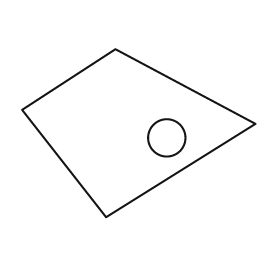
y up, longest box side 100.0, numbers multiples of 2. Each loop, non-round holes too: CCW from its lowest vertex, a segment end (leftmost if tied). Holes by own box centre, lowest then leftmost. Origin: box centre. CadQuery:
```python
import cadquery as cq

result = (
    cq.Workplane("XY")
    .moveTo(-14.0, -36.0)
    .lineTo(50.0, 4.0)
    .lineTo(-10.0, 36.0)
    .lineTo(-50.0, 10.0)
    .close()
    .moveTo(12.0, -2.0)
    .circle(8.0)
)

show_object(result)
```